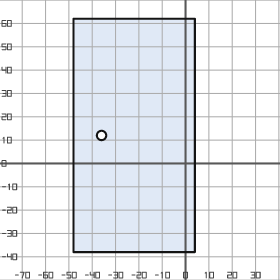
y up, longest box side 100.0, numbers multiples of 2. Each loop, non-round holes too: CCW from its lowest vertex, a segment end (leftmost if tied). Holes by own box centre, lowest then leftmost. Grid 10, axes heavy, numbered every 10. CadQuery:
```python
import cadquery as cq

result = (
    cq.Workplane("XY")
    .moveTo(-48.0, -38.0)
    .lineTo(4.0, -38.0)
    .lineTo(4.0, 62.0)
    .lineTo(-48.0, 62.0)
    .close()
    .moveTo(-36.0, 12.0)
    .circle(2.0)
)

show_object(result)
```